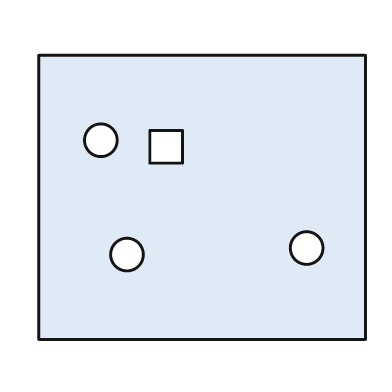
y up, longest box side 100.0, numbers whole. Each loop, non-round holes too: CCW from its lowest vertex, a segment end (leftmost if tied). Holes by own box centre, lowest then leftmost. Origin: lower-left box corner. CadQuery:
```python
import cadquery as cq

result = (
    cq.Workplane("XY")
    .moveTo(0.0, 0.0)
    .lineTo(100.0, 0.0)
    .lineTo(100.0, 87.0)
    .lineTo(0.0, 87.0)
    .close()
    .moveTo(27.0, 26.0)
    .circle(5.0)
    .moveTo(82.0, 28.0)
    .circle(5.0)
    .moveTo(34.0, 54.0)
    .lineTo(44.0, 54.0)
    .lineTo(44.0, 64.0)
    .lineTo(34.0, 64.0)
    .close()
    .moveTo(19.0, 61.0)
    .circle(5.0)
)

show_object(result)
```